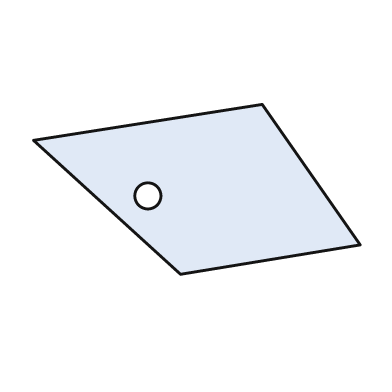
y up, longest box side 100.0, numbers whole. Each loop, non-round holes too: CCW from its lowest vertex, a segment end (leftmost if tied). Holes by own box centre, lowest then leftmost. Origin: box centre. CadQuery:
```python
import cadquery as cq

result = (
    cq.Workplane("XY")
    .moveTo(-5.0, -26.0)
    .lineTo(50.0, -17.0)
    .lineTo(20.0, 26.0)
    .lineTo(-50.0, 15.0)
    .close()
    .moveTo(-15.0, -2.0)
    .circle(4.0)
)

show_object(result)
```